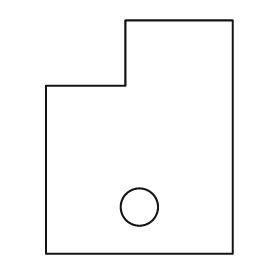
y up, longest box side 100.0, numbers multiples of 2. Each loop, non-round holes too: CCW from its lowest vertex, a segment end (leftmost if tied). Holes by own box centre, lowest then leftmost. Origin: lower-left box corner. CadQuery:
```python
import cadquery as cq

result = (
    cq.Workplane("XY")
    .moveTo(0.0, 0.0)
    .lineTo(80.0, 0.0)
    .lineTo(80.0, 100.0)
    .lineTo(34.0, 100.0)
    .lineTo(34.0, 72.0)
    .lineTo(0.0, 72.0)
    .close()
    .moveTo(40.0, 20.0)
    .circle(8.0)
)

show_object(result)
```